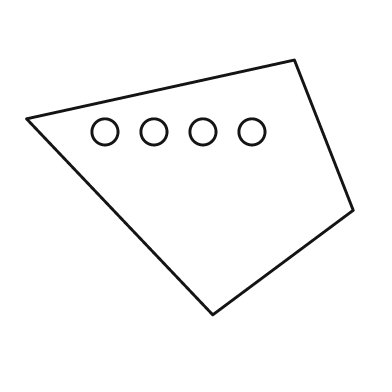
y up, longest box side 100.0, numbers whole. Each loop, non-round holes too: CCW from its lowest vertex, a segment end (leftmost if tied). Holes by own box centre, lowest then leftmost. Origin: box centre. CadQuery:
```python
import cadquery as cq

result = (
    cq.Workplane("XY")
    .moveTo(7.0, -39.0)
    .lineTo(50.0, -7.0)
    .lineTo(32.0, 39.0)
    .lineTo(-50.0, 21.0)
    .close()
    .moveTo(-26.0, 17.0)
    .circle(4.0)
    .moveTo(-11.0, 17.0)
    .circle(4.0)
    .moveTo(4.0, 17.0)
    .circle(4.0)
    .moveTo(19.0, 17.0)
    .circle(4.0)
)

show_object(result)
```